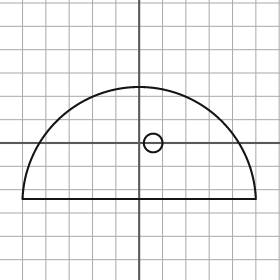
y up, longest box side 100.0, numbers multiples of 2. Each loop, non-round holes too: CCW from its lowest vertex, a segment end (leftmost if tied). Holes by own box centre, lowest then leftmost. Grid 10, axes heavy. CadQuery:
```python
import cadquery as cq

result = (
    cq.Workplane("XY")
    .moveTo(-50.0, -24.0)
    .lineTo(50.0, -24.0)
    .threePointArc((0.0, 24.0), (-50.0, -24.0))
    .close()
    .moveTo(6.0, 0.0)
    .circle(4.0)
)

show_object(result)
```